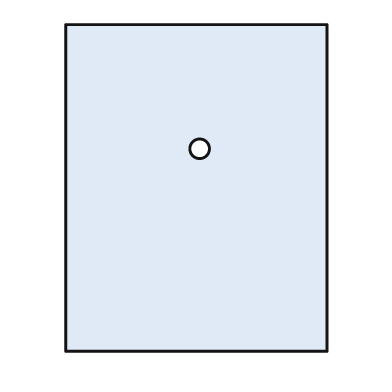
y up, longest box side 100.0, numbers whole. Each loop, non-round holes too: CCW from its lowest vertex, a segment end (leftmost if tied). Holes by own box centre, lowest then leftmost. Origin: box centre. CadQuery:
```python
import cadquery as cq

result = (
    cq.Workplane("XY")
    .moveTo(-40.0, -50.0)
    .lineTo(40.0, -50.0)
    .lineTo(40.0, 50.0)
    .lineTo(-40.0, 50.0)
    .close()
    .moveTo(1.0, 12.0)
    .circle(3.0)
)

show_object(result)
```